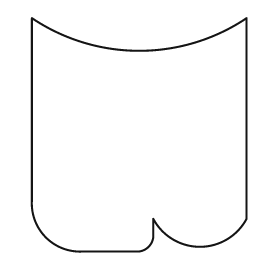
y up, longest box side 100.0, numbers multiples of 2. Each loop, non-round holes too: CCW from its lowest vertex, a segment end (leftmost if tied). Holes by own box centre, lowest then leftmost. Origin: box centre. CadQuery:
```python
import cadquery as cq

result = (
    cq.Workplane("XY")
    .moveTo(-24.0, -50.0)
    .lineTo(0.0, -50.0)
    .threePointArc((4.0, -48.0), (6.0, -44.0))
    .lineTo(6.0, -36.0)
    .threePointArc((26.0, -48.0), (46.0, -36.0))
    .lineTo(46.0, 50.0)
    .threePointArc((0.0, 36.0), (-46.0, 50.0))
    .lineTo(-46.0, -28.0)
    .threePointArc((-40.0, -44.0), (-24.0, -50.0))
    .close()
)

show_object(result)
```